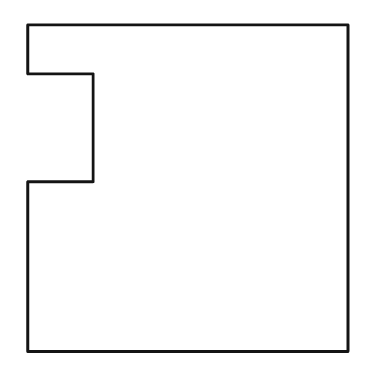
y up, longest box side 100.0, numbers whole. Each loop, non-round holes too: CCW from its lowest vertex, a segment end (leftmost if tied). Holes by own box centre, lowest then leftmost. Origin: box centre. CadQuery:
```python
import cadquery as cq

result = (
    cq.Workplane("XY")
    .moveTo(-49.0, -50.0)
    .lineTo(49.0, -50.0)
    .lineTo(49.0, 50.0)
    .lineTo(-49.0, 50.0)
    .lineTo(-49.0, 35.0)
    .lineTo(-29.0, 35.0)
    .lineTo(-29.0, 2.0)
    .lineTo(-49.0, 2.0)
    .close()
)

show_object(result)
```